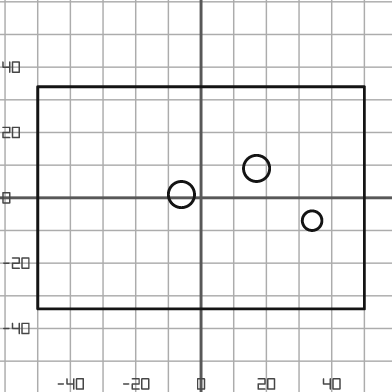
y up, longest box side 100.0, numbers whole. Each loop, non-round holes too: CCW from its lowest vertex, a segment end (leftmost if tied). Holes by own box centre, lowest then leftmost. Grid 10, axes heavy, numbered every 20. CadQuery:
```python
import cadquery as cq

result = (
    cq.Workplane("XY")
    .moveTo(-50.0, -34.0)
    .lineTo(50.0, -34.0)
    .lineTo(50.0, 34.0)
    .lineTo(-50.0, 34.0)
    .close()
    .moveTo(34.0, -7.0)
    .circle(3.0)
    .moveTo(-6.0, 1.0)
    .circle(4.0)
    .moveTo(17.0, 9.0)
    .circle(4.0)
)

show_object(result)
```